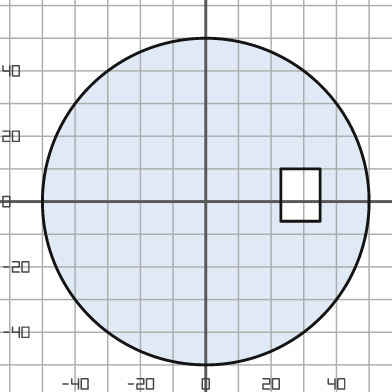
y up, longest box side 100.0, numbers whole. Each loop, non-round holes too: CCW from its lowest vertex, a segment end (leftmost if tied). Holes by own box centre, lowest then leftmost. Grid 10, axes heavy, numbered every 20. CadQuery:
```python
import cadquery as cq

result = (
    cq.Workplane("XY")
    .moveTo(0.0, 0.0)
    .circle(50.0)
    .moveTo(23.0, -6.0)
    .lineTo(35.0, -6.0)
    .lineTo(35.0, 10.0)
    .lineTo(23.0, 10.0)
    .close()
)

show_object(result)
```